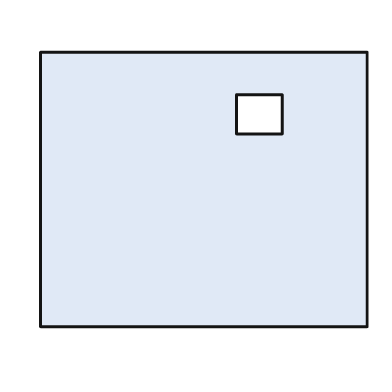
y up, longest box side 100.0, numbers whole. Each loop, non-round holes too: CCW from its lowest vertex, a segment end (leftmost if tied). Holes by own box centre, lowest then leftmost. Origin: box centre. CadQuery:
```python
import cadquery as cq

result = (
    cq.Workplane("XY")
    .moveTo(-50.0, -42.0)
    .lineTo(50.0, -42.0)
    .lineTo(50.0, 42.0)
    .lineTo(-50.0, 42.0)
    .close()
    .moveTo(10.0, 17.0)
    .lineTo(24.0, 17.0)
    .lineTo(24.0, 29.0)
    .lineTo(10.0, 29.0)
    .close()
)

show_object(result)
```